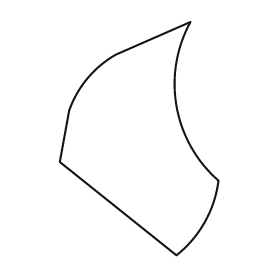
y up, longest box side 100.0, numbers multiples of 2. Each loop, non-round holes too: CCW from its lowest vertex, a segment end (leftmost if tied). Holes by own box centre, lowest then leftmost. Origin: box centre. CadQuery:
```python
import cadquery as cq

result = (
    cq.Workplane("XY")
    .moveTo(16.0, -50.0)
    .threePointArc((28.0, -36.0), (34.0, -18.0))
    .threePointArc((16.0, 14.0), (22.0, 50.0))
    .lineTo(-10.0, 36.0)
    .threePointArc((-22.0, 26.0), (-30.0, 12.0))
    .lineTo(-34.0, -10.0)
    .close()
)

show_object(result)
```